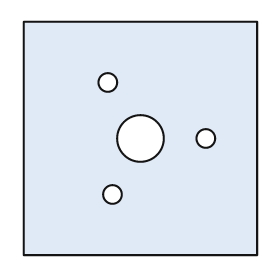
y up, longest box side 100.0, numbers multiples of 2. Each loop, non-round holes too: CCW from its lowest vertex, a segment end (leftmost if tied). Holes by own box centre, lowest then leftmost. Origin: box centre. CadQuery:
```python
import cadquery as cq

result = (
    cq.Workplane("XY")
    .moveTo(-50.0, -50.0)
    .lineTo(50.0, -50.0)
    .lineTo(50.0, 50.0)
    .lineTo(-50.0, 50.0)
    .close()
    .moveTo(-12.0, -24.0)
    .circle(4.0)
    .moveTo(0.0, 0.0)
    .circle(10.0)
    .moveTo(28.0, 0.0)
    .circle(4.0)
    .moveTo(-14.0, 24.0)
    .circle(4.0)
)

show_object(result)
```